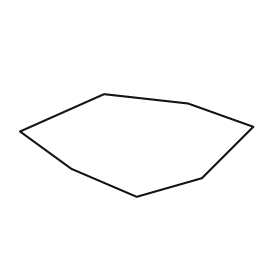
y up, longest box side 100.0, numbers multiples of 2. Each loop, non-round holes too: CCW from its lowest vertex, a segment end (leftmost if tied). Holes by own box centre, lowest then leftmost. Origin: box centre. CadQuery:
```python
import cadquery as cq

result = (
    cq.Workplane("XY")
    .moveTo(0.0, -22.0)
    .lineTo(28.0, -14.0)
    .lineTo(50.0, 8.0)
    .lineTo(22.0, 18.0)
    .lineTo(-14.0, 22.0)
    .lineTo(-50.0, 6.0)
    .lineTo(-28.0, -10.0)
    .close()
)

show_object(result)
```